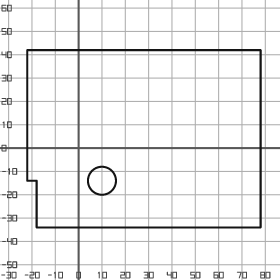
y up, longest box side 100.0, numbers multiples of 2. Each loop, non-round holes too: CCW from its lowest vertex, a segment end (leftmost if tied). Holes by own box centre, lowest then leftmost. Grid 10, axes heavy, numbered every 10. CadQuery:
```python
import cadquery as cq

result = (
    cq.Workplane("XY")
    .moveTo(-18.0, -34.0)
    .lineTo(78.0, -34.0)
    .lineTo(78.0, 42.0)
    .lineTo(-22.0, 42.0)
    .lineTo(-22.0, -14.0)
    .lineTo(-18.0, -14.0)
    .close()
    .moveTo(10.0, -14.0)
    .circle(6.0)
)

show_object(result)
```